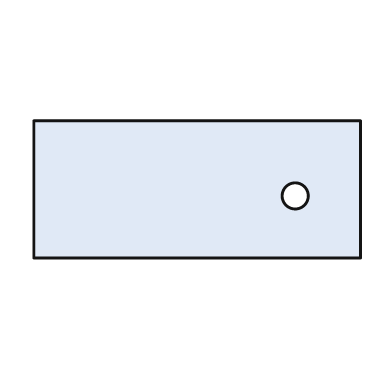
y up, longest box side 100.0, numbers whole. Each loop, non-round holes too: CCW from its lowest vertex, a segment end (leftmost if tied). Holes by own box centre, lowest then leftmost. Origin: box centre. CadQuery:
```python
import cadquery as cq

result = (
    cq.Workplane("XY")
    .moveTo(-50.0, -21.0)
    .lineTo(50.0, -21.0)
    .lineTo(50.0, 21.0)
    .lineTo(-50.0, 21.0)
    .close()
    .moveTo(30.0, -2.0)
    .circle(4.0)
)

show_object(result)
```